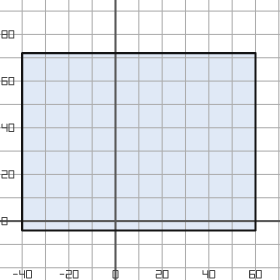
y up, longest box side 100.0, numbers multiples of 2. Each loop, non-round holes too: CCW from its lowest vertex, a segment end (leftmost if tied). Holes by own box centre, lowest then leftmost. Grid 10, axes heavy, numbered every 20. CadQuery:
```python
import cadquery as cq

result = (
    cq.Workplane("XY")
    .moveTo(-40.0, -4.0)
    .lineTo(60.0, -4.0)
    .lineTo(60.0, 72.0)
    .lineTo(-40.0, 72.0)
    .close()
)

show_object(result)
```